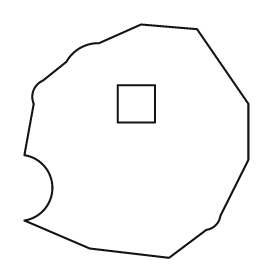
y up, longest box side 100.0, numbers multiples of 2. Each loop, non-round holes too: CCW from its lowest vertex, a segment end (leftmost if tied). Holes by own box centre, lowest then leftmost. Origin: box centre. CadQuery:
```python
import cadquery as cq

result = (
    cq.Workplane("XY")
    .moveTo(14.0, -50.0)
    .lineTo(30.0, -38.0)
    .threePointArc((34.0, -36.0), (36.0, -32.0))
    .lineTo(48.0, -8.0)
    .lineTo(48.0, 16.0)
    .lineTo(26.0, 48.0)
    .lineTo(2.0, 50.0)
    .lineTo(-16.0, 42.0)
    .threePointArc((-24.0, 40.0), (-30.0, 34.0))
    .lineTo(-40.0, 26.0)
    .threePointArc((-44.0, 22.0), (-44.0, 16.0))
    .lineTo(-48.0, -6.0)
    .threePointArc((-36.0, -20.0), (-48.0, -34.0))
    .lineTo(-20.0, -46.0)
    .close()
    .moveTo(-8.0, 8.0)
    .lineTo(8.0, 8.0)
    .lineTo(8.0, 24.0)
    .lineTo(-8.0, 24.0)
    .close()
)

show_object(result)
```